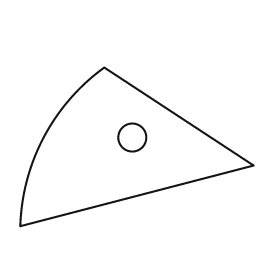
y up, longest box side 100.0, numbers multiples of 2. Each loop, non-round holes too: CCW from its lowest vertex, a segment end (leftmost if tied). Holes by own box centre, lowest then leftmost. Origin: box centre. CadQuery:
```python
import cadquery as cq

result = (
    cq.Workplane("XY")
    .moveTo(-50.0, -34.0)
    .lineTo(50.0, -8.0)
    .lineTo(-14.0, 34.0)
    .threePointArc((-40.0, 4.0), (-50.0, -34.0))
    .close()
    .moveTo(-2.0, 4.0)
    .circle(6.0)
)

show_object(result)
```